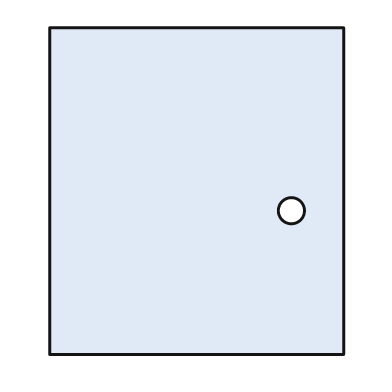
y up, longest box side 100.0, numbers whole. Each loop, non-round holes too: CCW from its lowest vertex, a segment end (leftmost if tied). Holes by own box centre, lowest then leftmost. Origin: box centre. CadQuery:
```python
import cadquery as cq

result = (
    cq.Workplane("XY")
    .moveTo(-45.0, -50.0)
    .lineTo(45.0, -50.0)
    .lineTo(45.0, 50.0)
    .lineTo(-45.0, 50.0)
    .close()
    .moveTo(29.0, -6.0)
    .circle(4.0)
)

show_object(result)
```